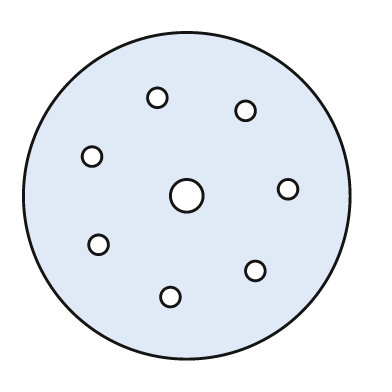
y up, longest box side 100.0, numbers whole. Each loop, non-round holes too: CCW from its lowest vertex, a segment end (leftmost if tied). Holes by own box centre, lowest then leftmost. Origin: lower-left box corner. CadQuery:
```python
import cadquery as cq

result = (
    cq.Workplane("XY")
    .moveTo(50.0, 50.0)
    .circle(50.0)
    .moveTo(45.0, 19.0)
    .circle(3.0)
    .moveTo(71.0, 27.0)
    .circle(3.0)
    .moveTo(23.0, 35.0)
    .circle(3.0)
    .moveTo(50.0, 50.0)
    .circle(5.0)
    .moveTo(81.0, 52.0)
    .circle(3.0)
    .moveTo(21.0, 62.0)
    .circle(3.0)
    .moveTo(68.0, 76.0)
    .circle(3.0)
    .moveTo(41.0, 80.0)
    .circle(3.0)
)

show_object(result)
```